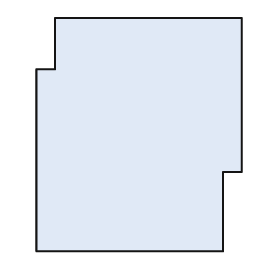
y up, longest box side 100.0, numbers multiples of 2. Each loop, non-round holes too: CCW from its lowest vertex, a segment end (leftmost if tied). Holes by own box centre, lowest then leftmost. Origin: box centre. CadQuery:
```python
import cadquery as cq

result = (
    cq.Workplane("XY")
    .moveTo(-44.0, -50.0)
    .lineTo(36.0, -50.0)
    .lineTo(36.0, -16.0)
    .lineTo(44.0, -16.0)
    .lineTo(44.0, 50.0)
    .lineTo(-36.0, 50.0)
    .lineTo(-36.0, 28.0)
    .lineTo(-44.0, 28.0)
    .close()
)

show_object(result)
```